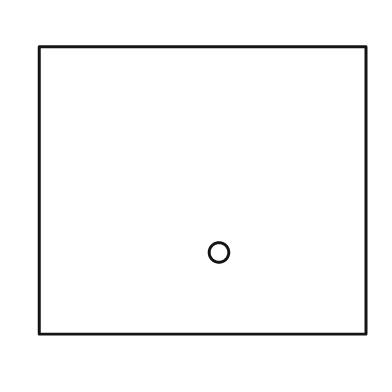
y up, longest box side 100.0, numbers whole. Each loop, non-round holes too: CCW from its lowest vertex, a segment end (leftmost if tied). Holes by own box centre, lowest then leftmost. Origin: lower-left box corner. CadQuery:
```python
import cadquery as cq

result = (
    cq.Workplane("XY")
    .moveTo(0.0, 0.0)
    .lineTo(100.0, 0.0)
    .lineTo(100.0, 88.0)
    .lineTo(0.0, 88.0)
    .close()
    .moveTo(55.0, 25.0)
    .circle(3.0)
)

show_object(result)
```